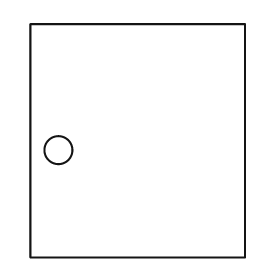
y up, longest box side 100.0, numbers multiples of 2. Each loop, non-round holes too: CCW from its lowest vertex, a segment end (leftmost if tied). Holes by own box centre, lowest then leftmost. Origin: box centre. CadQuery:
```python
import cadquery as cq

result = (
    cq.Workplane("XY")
    .moveTo(-46.0, -50.0)
    .lineTo(46.0, -50.0)
    .lineTo(46.0, 50.0)
    .lineTo(-46.0, 50.0)
    .close()
    .moveTo(-34.0, -4.0)
    .circle(6.0)
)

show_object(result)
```